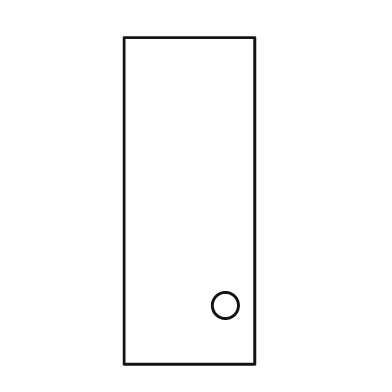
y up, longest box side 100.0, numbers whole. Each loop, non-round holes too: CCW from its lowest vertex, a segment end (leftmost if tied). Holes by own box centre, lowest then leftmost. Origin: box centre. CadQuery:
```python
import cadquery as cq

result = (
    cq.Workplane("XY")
    .moveTo(-20.0, -50.0)
    .lineTo(20.0, -50.0)
    .lineTo(20.0, 50.0)
    .lineTo(-20.0, 50.0)
    .close()
    .moveTo(11.0, -32.0)
    .circle(4.0)
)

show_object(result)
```